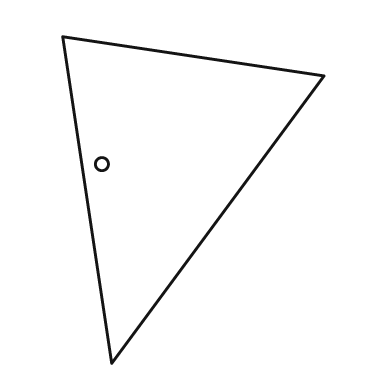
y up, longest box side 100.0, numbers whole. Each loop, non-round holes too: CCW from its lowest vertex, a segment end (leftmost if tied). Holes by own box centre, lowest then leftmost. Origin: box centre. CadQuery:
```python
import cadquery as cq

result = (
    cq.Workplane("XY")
    .moveTo(-25.0, -50.0)
    .lineTo(40.0, 38.0)
    .lineTo(-40.0, 50.0)
    .close()
    .moveTo(-28.0, 11.0)
    .circle(2.0)
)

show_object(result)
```